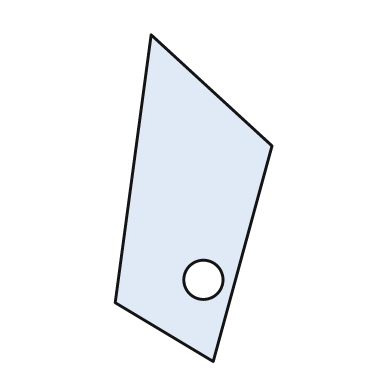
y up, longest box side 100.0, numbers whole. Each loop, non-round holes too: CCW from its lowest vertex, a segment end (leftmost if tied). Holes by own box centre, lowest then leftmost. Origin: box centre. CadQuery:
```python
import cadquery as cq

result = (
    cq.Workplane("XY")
    .moveTo(6.0, -50.0)
    .lineTo(24.0, 16.0)
    .lineTo(-13.0, 50.0)
    .lineTo(-24.0, -32.0)
    .close()
    .moveTo(3.0, -25.0)
    .circle(6.0)
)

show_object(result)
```